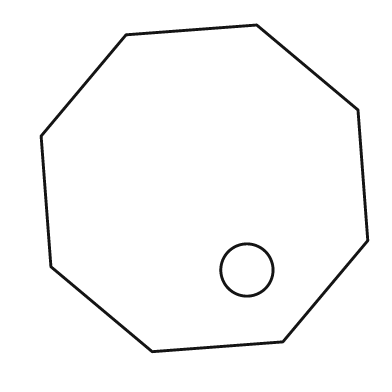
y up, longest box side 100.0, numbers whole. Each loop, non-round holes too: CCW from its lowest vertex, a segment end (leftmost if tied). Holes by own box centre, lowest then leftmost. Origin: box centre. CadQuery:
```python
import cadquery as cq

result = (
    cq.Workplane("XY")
    .moveTo(-16.0, -50.0)
    .lineTo(24.0, -47.0)
    .lineTo(50.0, -16.0)
    .lineTo(47.0, 24.0)
    .lineTo(16.0, 50.0)
    .lineTo(-24.0, 47.0)
    .lineTo(-50.0, 16.0)
    .lineTo(-47.0, -24.0)
    .close()
    .moveTo(13.0, -25.0)
    .circle(8.0)
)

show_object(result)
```